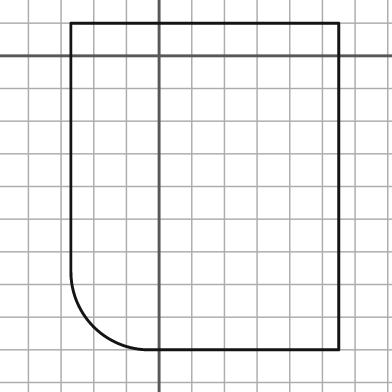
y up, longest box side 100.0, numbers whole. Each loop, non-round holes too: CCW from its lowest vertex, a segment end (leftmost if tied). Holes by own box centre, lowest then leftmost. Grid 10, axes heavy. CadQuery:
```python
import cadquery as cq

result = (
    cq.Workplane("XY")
    .moveTo(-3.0, -90.0)
    .lineTo(55.0, -90.0)
    .lineTo(55.0, 10.0)
    .lineTo(-27.0, 10.0)
    .lineTo(-27.0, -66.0)
    .threePointArc((-20.0, -83.0), (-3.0, -90.0))
    .close()
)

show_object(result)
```